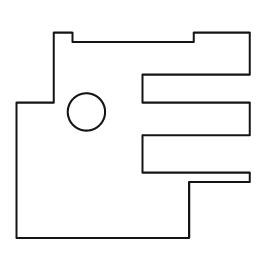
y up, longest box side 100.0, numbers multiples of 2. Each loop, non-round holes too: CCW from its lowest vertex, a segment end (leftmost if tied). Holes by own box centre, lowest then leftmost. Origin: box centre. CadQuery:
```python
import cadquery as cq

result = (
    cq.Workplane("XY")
    .moveTo(-50.0, -44.0)
    .lineTo(24.0, -44.0)
    .lineTo(24.0, -20.0)
    .lineTo(50.0, -20.0)
    .lineTo(50.0, -16.0)
    .lineTo(4.0, -16.0)
    .lineTo(4.0, 0.0)
    .lineTo(50.0, 0.0)
    .lineTo(50.0, 14.0)
    .lineTo(4.0, 14.0)
    .lineTo(4.0, 26.0)
    .lineTo(50.0, 26.0)
    .lineTo(50.0, 44.0)
    .lineTo(26.0, 44.0)
    .lineTo(26.0, 40.0)
    .lineTo(-26.0, 40.0)
    .lineTo(-26.0, 44.0)
    .lineTo(-34.0, 44.0)
    .lineTo(-34.0, 14.0)
    .lineTo(-50.0, 14.0)
    .close()
    .moveTo(-20.0, 10.0)
    .circle(8.0)
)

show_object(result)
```